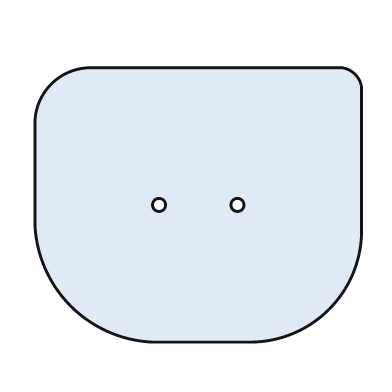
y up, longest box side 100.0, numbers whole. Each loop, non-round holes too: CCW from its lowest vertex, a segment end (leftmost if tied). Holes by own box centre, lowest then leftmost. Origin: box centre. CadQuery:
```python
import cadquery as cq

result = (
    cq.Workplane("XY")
    .moveTo(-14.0, -42.0)
    .lineTo(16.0, -42.0)
    .threePointArc((40.0, -32.0), (50.0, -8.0))
    .lineTo(50.0, 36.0)
    .threePointArc((48.0, 40.0), (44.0, 42.0))
    .lineTo(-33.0, 42.0)
    .threePointArc((-45.0, 37.0), (-50.0, 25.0))
    .lineTo(-50.0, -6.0)
    .threePointArc((-39.0, -31.0), (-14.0, -42.0))
    .close()
    .moveTo(-12.0, 0.0)
    .circle(2.0)
    .moveTo(12.0, 0.0)
    .circle(2.0)
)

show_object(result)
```